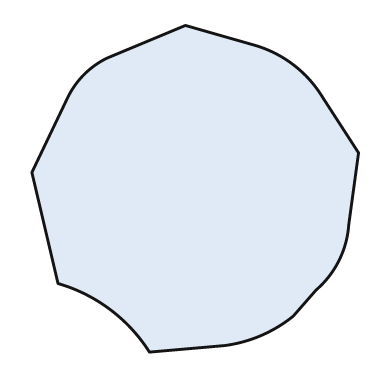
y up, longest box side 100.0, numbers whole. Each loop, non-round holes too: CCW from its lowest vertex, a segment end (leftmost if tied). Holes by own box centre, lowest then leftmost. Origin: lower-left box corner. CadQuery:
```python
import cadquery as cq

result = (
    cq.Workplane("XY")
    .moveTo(36.0, 0.0)
    .lineTo(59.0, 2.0)
    .threePointArc((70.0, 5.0), (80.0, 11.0))
    .lineTo(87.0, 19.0)
    .threePointArc((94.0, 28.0), (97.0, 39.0))
    .lineTo(100.0, 61.0)
    .lineTo(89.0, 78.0)
    .threePointArc((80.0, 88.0), (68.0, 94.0))
    .lineTo(47.0, 100.0)
    .lineTo(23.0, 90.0)
    .threePointArc((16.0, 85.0), (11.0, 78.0))
    .lineTo(0.0, 55.0)
    .lineTo(8.0, 21.0)
    .threePointArc((24.0, 13.0), (36.0, 0.0))
    .close()
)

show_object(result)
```